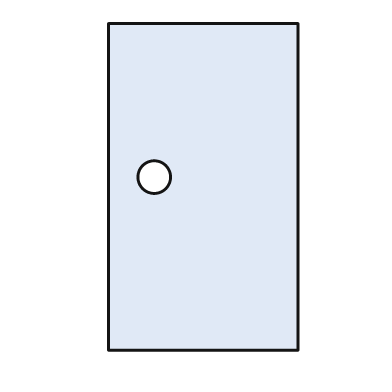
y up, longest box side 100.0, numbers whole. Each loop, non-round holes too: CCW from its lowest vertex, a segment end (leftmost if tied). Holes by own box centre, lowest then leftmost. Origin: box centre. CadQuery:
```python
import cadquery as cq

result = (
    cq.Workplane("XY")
    .moveTo(-29.0, -50.0)
    .lineTo(29.0, -50.0)
    .lineTo(29.0, 50.0)
    .lineTo(-29.0, 50.0)
    .close()
    .moveTo(-15.0, 3.0)
    .circle(5.0)
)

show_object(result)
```